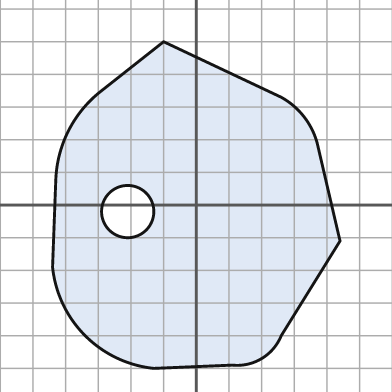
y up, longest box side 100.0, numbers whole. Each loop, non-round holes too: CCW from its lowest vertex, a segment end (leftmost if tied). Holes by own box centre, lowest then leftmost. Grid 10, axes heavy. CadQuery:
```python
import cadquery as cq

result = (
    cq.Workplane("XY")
    .moveTo(-13.0, -50.0)
    .lineTo(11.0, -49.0)
    .threePointArc((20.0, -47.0), (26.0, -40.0))
    .lineTo(44.0, -11.0)
    .lineTo(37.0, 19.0)
    .threePointArc((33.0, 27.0), (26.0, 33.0))
    .lineTo(-10.0, 50.0)
    .lineTo(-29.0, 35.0)
    .threePointArc((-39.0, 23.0), (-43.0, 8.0))
    .lineTo(-44.0, -19.0)
    .threePointArc((-34.0, -40.0), (-13.0, -50.0))
    .close()
    .moveTo(-21.0, -2.0)
    .circle(8.0)
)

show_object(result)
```